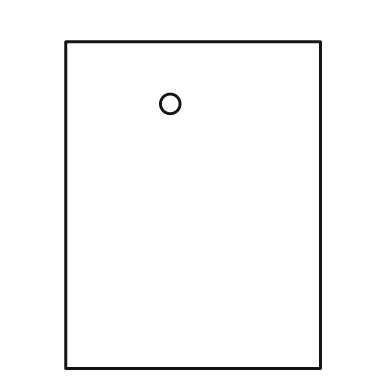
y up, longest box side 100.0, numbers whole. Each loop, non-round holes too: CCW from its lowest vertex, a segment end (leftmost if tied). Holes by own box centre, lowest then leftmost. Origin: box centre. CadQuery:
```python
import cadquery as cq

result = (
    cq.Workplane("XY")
    .moveTo(-39.0, -50.0)
    .lineTo(39.0, -50.0)
    .lineTo(39.0, 50.0)
    .lineTo(-39.0, 50.0)
    .close()
    .moveTo(-7.0, 31.0)
    .circle(3.0)
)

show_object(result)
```